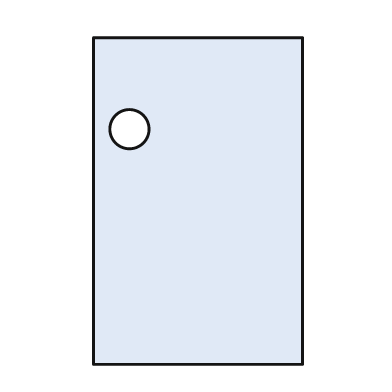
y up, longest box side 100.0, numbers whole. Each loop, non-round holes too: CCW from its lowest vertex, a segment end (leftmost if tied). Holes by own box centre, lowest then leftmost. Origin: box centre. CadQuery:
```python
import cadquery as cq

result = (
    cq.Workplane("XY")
    .moveTo(-32.0, -50.0)
    .lineTo(32.0, -50.0)
    .lineTo(32.0, 50.0)
    .lineTo(-32.0, 50.0)
    .close()
    .moveTo(-21.0, 22.0)
    .circle(6.0)
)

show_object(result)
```